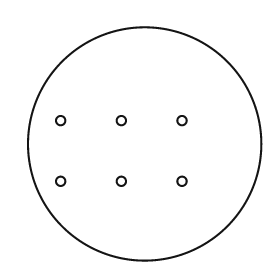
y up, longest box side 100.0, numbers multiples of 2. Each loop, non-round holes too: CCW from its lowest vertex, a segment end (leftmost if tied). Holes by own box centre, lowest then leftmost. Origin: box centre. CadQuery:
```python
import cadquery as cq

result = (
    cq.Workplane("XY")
    .moveTo(0.0, 0.0)
    .circle(50.0)
    .moveTo(-36.0, -16.0)
    .circle(2.0)
    .moveTo(-10.0, -16.0)
    .circle(2.0)
    .moveTo(16.0, -16.0)
    .circle(2.0)
    .moveTo(-36.0, 10.0)
    .circle(2.0)
    .moveTo(-10.0, 10.0)
    .circle(2.0)
    .moveTo(16.0, 10.0)
    .circle(2.0)
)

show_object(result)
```